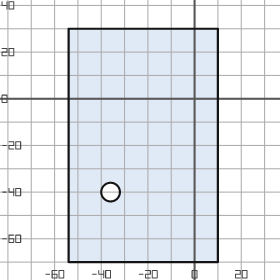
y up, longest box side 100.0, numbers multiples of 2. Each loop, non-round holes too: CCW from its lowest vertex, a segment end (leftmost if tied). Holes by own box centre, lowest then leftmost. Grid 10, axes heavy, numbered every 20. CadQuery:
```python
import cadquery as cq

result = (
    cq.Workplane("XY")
    .moveTo(-54.0, -70.0)
    .lineTo(10.0, -70.0)
    .lineTo(10.0, 30.0)
    .lineTo(-54.0, 30.0)
    .close()
    .moveTo(-36.0, -40.0)
    .circle(4.0)
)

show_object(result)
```